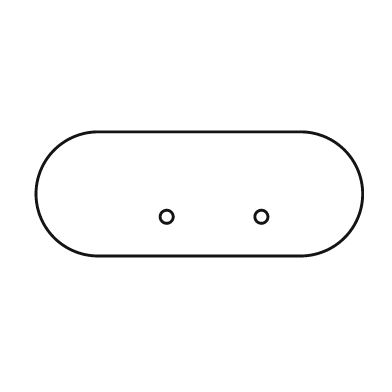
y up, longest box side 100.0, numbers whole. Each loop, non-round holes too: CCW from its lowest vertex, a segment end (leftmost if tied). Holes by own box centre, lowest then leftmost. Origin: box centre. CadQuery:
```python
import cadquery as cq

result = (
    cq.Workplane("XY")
    .moveTo(-31.0, -19.0)
    .lineTo(31.0, -19.0)
    .threePointArc((50.0, 0.0), (31.0, 19.0))
    .lineTo(-31.0, 19.0)
    .threePointArc((-50.0, 0.0), (-31.0, -19.0))
    .close()
    .moveTo(-10.0, -7.0)
    .circle(2.0)
    .moveTo(19.0, -7.0)
    .circle(2.0)
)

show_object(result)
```